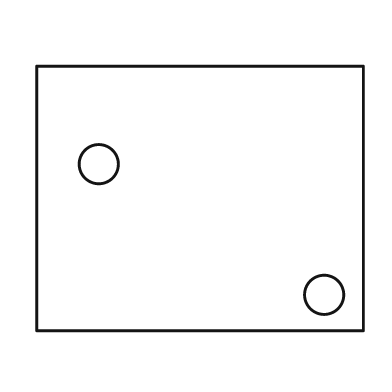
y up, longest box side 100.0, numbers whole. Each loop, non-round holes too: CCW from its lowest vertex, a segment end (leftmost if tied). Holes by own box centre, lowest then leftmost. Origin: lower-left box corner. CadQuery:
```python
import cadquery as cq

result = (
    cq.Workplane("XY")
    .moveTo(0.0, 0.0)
    .lineTo(100.0, 0.0)
    .lineTo(100.0, 81.0)
    .lineTo(0.0, 81.0)
    .close()
    .moveTo(88.0, 11.0)
    .circle(6.0)
    .moveTo(19.0, 51.0)
    .circle(6.0)
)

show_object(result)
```